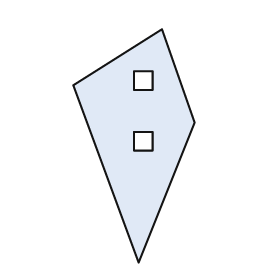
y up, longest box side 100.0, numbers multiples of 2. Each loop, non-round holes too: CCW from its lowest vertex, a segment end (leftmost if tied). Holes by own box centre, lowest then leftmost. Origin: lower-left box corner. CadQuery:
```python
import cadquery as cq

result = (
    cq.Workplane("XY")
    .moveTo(28.0, 0.0)
    .lineTo(52.0, 60.0)
    .lineTo(38.0, 100.0)
    .lineTo(0.0, 76.0)
    .close()
    .moveTo(26.0, 48.0)
    .lineTo(34.0, 48.0)
    .lineTo(34.0, 56.0)
    .lineTo(26.0, 56.0)
    .close()
    .moveTo(26.0, 74.0)
    .lineTo(34.0, 74.0)
    .lineTo(34.0, 82.0)
    .lineTo(26.0, 82.0)
    .close()
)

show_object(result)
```